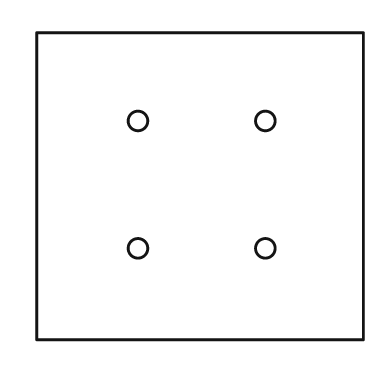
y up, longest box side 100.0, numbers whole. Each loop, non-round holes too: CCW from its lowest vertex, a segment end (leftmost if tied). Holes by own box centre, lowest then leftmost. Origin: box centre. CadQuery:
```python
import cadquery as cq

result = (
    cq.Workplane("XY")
    .moveTo(-50.0, -47.0)
    .lineTo(50.0, -47.0)
    .lineTo(50.0, 47.0)
    .lineTo(-50.0, 47.0)
    .close()
    .moveTo(-19.0, -19.0)
    .circle(3.0)
    .moveTo(20.0, -19.0)
    .circle(3.0)
    .moveTo(-19.0, 20.0)
    .circle(3.0)
    .moveTo(20.0, 20.0)
    .circle(3.0)
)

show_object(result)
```